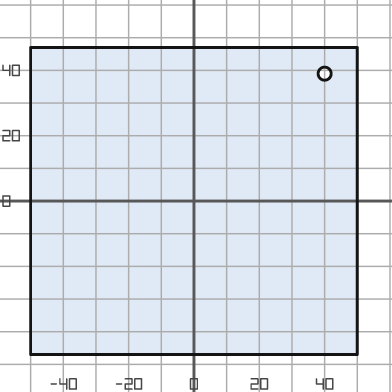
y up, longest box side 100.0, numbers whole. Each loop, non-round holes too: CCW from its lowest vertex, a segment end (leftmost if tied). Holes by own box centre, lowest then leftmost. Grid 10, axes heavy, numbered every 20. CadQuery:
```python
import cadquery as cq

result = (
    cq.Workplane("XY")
    .moveTo(-50.0, -47.0)
    .lineTo(50.0, -47.0)
    .lineTo(50.0, 47.0)
    .lineTo(-50.0, 47.0)
    .close()
    .moveTo(40.0, 39.0)
    .circle(2.0)
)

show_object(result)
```